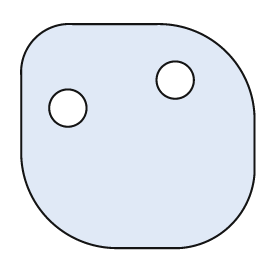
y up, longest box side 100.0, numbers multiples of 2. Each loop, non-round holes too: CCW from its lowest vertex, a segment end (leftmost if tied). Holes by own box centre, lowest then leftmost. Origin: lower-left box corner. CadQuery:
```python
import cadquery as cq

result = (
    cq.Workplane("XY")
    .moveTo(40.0, 0.0)
    .lineTo(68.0, 0.0)
    .threePointArc((90.0, 10.0), (100.0, 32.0))
    .lineTo(100.0, 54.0)
    .threePointArc((88.0, 84.0), (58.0, 96.0))
    .lineTo(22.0, 96.0)
    .threePointArc((6.0, 90.0), (0.0, 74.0))
    .lineTo(0.0, 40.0)
    .threePointArc((12.0, 12.0), (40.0, 0.0))
    .close()
    .moveTo(20.0, 60.0)
    .circle(8.0)
    .moveTo(66.0, 72.0)
    .circle(8.0)
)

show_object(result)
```